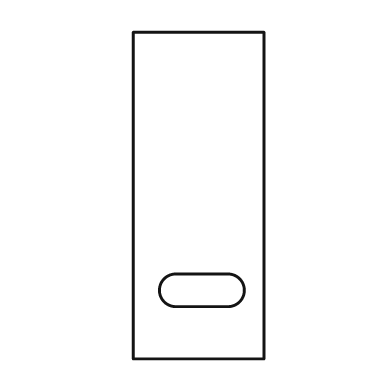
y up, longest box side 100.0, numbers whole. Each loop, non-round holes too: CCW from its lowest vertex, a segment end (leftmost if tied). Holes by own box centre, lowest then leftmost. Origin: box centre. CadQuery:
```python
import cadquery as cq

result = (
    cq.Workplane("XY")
    .moveTo(-20.0, -50.0)
    .lineTo(20.0, -50.0)
    .lineTo(20.0, 50.0)
    .lineTo(-20.0, 50.0)
    .close()
    .moveTo(-7.0, -34.0)
    .lineTo(9.0, -34.0)
    .threePointArc((14.0, -29.0), (9.0, -24.0))
    .lineTo(-7.0, -24.0)
    .threePointArc((-12.0, -29.0), (-7.0, -34.0))
    .close()
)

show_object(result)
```